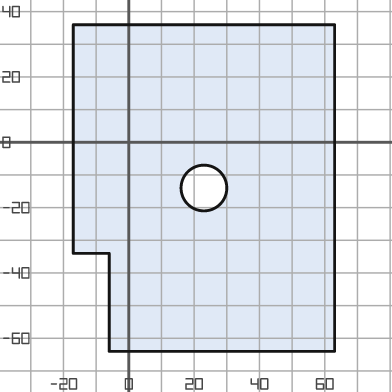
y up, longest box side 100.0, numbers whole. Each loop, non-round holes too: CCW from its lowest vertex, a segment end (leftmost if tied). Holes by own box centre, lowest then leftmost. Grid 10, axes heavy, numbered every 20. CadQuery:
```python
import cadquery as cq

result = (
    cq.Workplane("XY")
    .moveTo(-6.0, -64.0)
    .lineTo(63.0, -64.0)
    .lineTo(63.0, 36.0)
    .lineTo(-17.0, 36.0)
    .lineTo(-17.0, -34.0)
    .lineTo(-6.0, -34.0)
    .close()
    .moveTo(23.0, -14.0)
    .circle(7.0)
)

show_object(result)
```